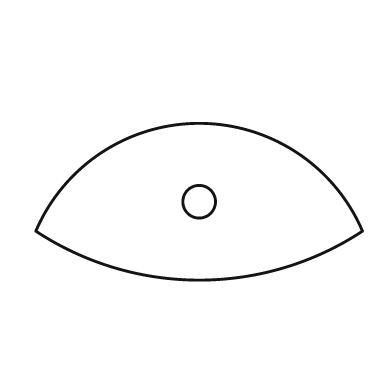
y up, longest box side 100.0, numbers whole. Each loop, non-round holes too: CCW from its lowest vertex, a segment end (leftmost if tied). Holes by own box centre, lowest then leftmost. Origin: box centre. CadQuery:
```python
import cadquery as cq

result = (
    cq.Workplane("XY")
    .moveTo(-50.0, -9.0)
    .threePointArc((0.0, -24.0), (50.0, -9.0))
    .threePointArc((0.0, 24.0), (-50.0, -9.0))
    .close()
    .moveTo(0.0, 0.0)
    .circle(5.0)
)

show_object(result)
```